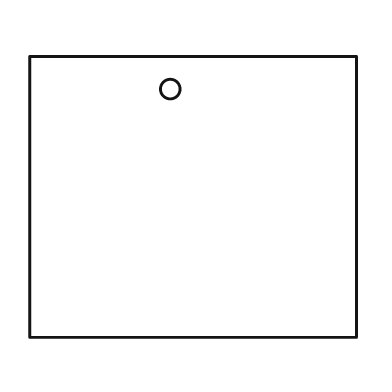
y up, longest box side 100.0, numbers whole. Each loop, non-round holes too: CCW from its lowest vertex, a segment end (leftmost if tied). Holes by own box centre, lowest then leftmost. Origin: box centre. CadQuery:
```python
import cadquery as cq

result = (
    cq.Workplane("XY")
    .moveTo(-50.0, -43.0)
    .lineTo(50.0, -43.0)
    .lineTo(50.0, 43.0)
    .lineTo(-50.0, 43.0)
    .close()
    .moveTo(-7.0, 33.0)
    .circle(3.0)
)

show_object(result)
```